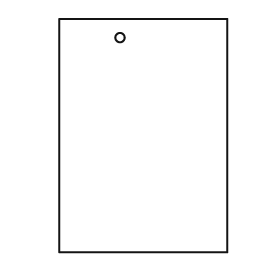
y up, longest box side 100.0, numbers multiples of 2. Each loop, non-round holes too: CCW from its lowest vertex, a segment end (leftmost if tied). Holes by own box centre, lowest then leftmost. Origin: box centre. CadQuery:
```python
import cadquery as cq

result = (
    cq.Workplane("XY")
    .moveTo(-36.0, -50.0)
    .lineTo(36.0, -50.0)
    .lineTo(36.0, 50.0)
    .lineTo(-36.0, 50.0)
    .close()
    .moveTo(-10.0, 42.0)
    .circle(2.0)
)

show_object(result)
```